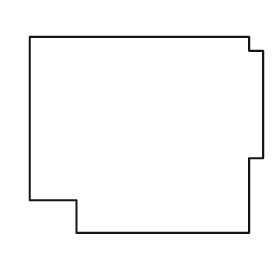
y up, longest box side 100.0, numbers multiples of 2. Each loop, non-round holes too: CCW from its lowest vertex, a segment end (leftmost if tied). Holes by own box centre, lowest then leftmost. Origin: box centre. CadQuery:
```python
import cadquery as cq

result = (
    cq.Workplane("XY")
    .moveTo(-30.0, -42.0)
    .lineTo(44.0, -42.0)
    .lineTo(44.0, -10.0)
    .lineTo(50.0, -10.0)
    .lineTo(50.0, 36.0)
    .lineTo(44.0, 36.0)
    .lineTo(44.0, 42.0)
    .lineTo(-50.0, 42.0)
    .lineTo(-50.0, -28.0)
    .lineTo(-30.0, -28.0)
    .close()
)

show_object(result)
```